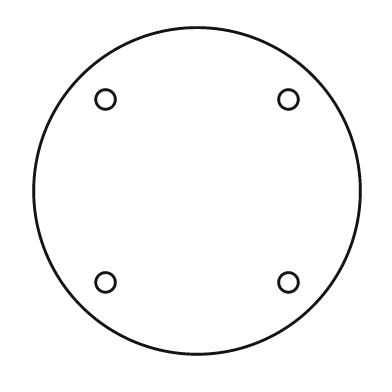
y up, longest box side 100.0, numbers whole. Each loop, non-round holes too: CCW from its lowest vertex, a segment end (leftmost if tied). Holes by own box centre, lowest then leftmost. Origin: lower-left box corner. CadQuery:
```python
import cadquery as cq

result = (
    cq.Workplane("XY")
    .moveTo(50.0, 50.0)
    .circle(50.0)
    .moveTo(22.0, 22.0)
    .circle(3.0)
    .moveTo(78.0, 22.0)
    .circle(3.0)
    .moveTo(22.0, 78.0)
    .circle(3.0)
    .moveTo(78.0, 78.0)
    .circle(3.0)
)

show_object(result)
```